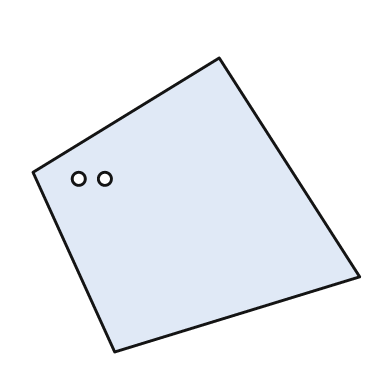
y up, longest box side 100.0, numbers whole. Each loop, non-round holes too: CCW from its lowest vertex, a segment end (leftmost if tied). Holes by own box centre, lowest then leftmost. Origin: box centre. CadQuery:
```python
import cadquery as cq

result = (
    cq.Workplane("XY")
    .moveTo(-25.0, -45.0)
    .lineTo(50.0, -22.0)
    .lineTo(7.0, 45.0)
    .lineTo(-50.0, 10.0)
    .close()
    .moveTo(-36.0, 8.0)
    .circle(2.0)
    .moveTo(-28.0, 8.0)
    .circle(2.0)
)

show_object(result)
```